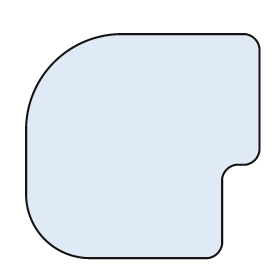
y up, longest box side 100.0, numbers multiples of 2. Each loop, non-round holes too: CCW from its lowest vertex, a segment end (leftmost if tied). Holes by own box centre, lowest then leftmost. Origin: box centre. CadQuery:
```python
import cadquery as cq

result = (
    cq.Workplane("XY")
    .moveTo(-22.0, -48.0)
    .lineTo(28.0, -48.0)
    .threePointArc((32.0, -46.0), (34.0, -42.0))
    .lineTo(34.0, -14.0)
    .threePointArc((36.0, -10.0), (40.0, -8.0))
    .lineTo(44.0, -8.0)
    .threePointArc((48.0, -6.0), (50.0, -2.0))
    .lineTo(50.0, 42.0)
    .threePointArc((48.0, 46.0), (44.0, 48.0))
    .lineTo(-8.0, 48.0)
    .threePointArc((-38.0, 36.0), (-50.0, 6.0))
    .lineTo(-50.0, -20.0)
    .threePointArc((-42.0, -40.0), (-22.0, -48.0))
    .close()
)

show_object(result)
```